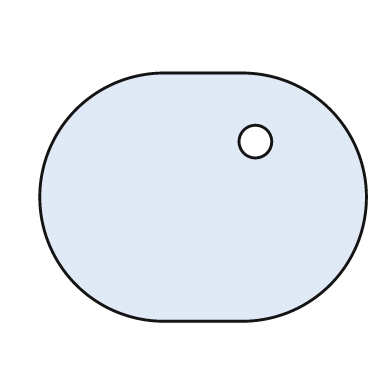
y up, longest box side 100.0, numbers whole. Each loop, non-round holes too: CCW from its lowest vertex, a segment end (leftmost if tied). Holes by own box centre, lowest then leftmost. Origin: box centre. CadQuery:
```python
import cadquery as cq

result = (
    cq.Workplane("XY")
    .moveTo(-12.0, -38.0)
    .lineTo(12.0, -38.0)
    .threePointArc((50.0, 0.0), (12.0, 38.0))
    .lineTo(-12.0, 38.0)
    .threePointArc((-50.0, 0.0), (-12.0, -38.0))
    .close()
    .moveTo(16.0, 17.0)
    .circle(5.0)
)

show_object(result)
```